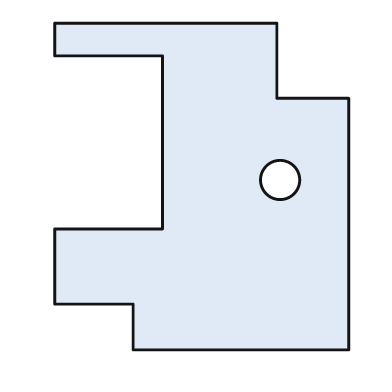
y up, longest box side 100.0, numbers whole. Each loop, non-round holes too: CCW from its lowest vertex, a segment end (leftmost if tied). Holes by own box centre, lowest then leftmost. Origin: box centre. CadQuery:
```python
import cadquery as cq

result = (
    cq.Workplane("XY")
    .moveTo(-21.0, -50.0)
    .lineTo(45.0, -50.0)
    .lineTo(45.0, 27.0)
    .lineTo(23.0, 27.0)
    .lineTo(23.0, 50.0)
    .lineTo(-45.0, 50.0)
    .lineTo(-45.0, 40.0)
    .lineTo(-12.0, 40.0)
    .lineTo(-12.0, -13.0)
    .lineTo(-45.0, -13.0)
    .lineTo(-45.0, -36.0)
    .lineTo(-21.0, -36.0)
    .close()
    .moveTo(24.0, 2.0)
    .circle(6.0)
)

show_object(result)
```